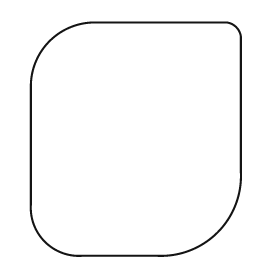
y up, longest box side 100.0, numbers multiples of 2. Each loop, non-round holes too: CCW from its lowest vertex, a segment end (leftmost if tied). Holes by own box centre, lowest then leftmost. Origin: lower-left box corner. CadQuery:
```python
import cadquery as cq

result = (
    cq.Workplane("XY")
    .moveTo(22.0, 0.0)
    .lineTo(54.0, 0.0)
    .threePointArc((80.0, 10.0), (90.0, 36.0))
    .lineTo(90.0, 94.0)
    .threePointArc((88.0, 98.0), (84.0, 100.0))
    .lineTo(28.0, 100.0)
    .threePointArc((8.0, 92.0), (0.0, 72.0))
    .lineTo(0.0, 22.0)
    .threePointArc((6.0, 6.0), (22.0, 0.0))
    .close()
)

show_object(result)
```